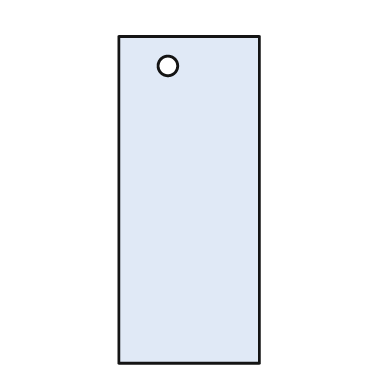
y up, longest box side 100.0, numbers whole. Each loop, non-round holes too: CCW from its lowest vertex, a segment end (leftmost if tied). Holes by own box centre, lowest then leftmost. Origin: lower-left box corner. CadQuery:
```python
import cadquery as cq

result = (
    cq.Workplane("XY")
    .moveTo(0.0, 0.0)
    .lineTo(43.0, 0.0)
    .lineTo(43.0, 100.0)
    .lineTo(0.0, 100.0)
    .close()
    .moveTo(15.0, 91.0)
    .circle(3.0)
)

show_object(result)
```